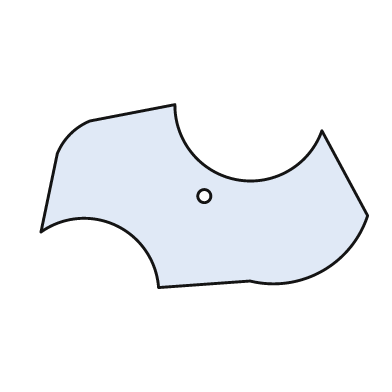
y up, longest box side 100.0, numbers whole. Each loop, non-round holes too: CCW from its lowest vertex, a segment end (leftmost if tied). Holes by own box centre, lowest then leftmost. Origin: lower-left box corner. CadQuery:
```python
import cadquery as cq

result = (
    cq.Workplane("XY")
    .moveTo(36.0, 0.0)
    .lineTo(64.0, 2.0)
    .threePointArc((86.0, 5.0), (100.0, 22.0))
    .lineTo(86.0, 48.0)
    .threePointArc((60.0, 33.0), (41.0, 56.0))
    .lineTo(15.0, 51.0)
    .threePointArc((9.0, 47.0), (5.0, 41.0))
    .lineTo(0.0, 17.0)
    .threePointArc((23.0, 19.0), (36.0, 0.0))
    .close()
    .moveTo(50.0, 28.0)
    .circle(2.0)
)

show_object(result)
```